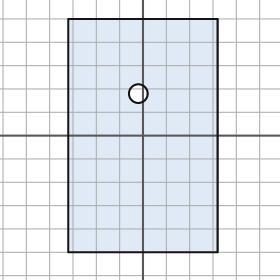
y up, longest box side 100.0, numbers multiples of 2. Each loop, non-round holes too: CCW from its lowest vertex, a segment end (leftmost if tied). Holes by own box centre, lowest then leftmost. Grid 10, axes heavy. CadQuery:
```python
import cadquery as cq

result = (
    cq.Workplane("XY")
    .moveTo(-32.0, -50.0)
    .lineTo(32.0, -50.0)
    .lineTo(32.0, 50.0)
    .lineTo(-32.0, 50.0)
    .close()
    .moveTo(-2.0, 18.0)
    .circle(4.0)
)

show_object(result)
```